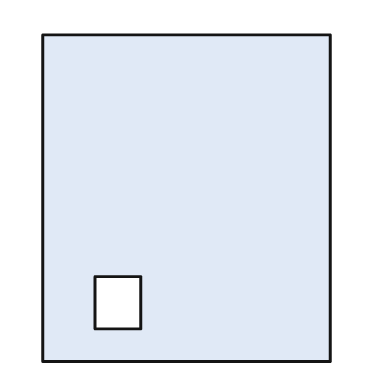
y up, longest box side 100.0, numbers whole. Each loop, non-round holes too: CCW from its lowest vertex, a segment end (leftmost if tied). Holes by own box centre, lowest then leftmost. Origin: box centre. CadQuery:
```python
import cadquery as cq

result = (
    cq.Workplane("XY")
    .moveTo(-44.0, -50.0)
    .lineTo(44.0, -50.0)
    .lineTo(44.0, 50.0)
    .lineTo(-44.0, 50.0)
    .close()
    .moveTo(-28.0, -40.0)
    .lineTo(-14.0, -40.0)
    .lineTo(-14.0, -24.0)
    .lineTo(-28.0, -24.0)
    .close()
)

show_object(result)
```